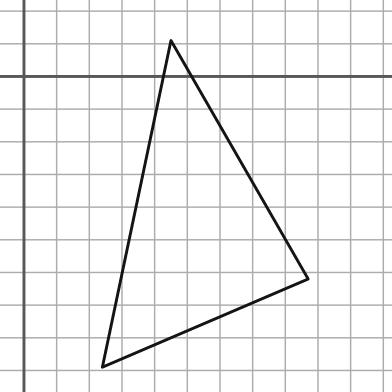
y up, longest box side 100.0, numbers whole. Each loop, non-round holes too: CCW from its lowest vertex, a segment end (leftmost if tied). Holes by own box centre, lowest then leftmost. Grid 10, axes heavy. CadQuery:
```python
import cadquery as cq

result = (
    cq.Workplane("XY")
    .moveTo(24.0, -89.0)
    .lineTo(87.0, -62.0)
    .lineTo(45.0, 11.0)
    .close()
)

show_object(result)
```